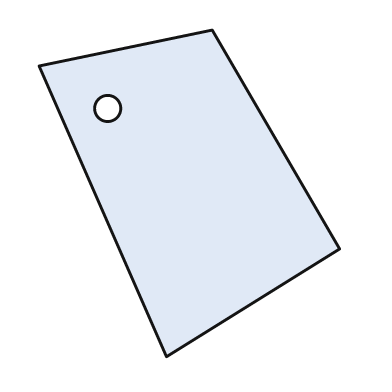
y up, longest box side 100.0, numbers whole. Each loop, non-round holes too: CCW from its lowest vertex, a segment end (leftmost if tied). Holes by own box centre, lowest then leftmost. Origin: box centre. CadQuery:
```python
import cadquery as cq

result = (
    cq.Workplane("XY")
    .moveTo(-7.0, -50.0)
    .lineTo(46.0, -17.0)
    .lineTo(7.0, 50.0)
    .lineTo(-46.0, 39.0)
    .close()
    .moveTo(-25.0, 26.0)
    .circle(4.0)
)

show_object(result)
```